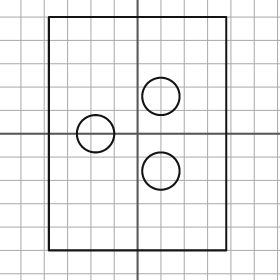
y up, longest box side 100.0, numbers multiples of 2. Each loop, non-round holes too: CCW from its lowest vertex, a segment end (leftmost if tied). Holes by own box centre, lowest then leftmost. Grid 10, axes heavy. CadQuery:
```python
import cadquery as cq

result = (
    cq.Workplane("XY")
    .moveTo(-38.0, -50.0)
    .lineTo(38.0, -50.0)
    .lineTo(38.0, 50.0)
    .lineTo(-38.0, 50.0)
    .close()
    .moveTo(10.0, -16.0)
    .circle(8.0)
    .moveTo(-18.0, 0.0)
    .circle(8.0)
    .moveTo(10.0, 16.0)
    .circle(8.0)
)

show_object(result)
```